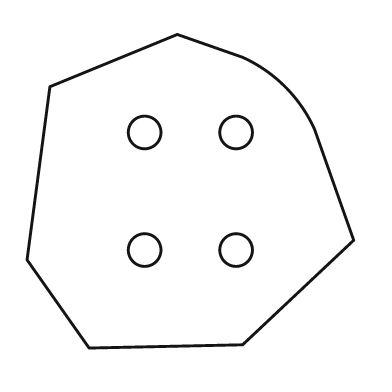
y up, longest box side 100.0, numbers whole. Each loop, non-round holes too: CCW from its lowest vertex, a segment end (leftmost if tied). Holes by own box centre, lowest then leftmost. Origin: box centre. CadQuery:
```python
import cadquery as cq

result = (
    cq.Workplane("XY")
    .moveTo(-31.0, -48.0)
    .lineTo(16.0, -47.0)
    .lineTo(50.0, -15.0)
    .lineTo(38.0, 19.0)
    .threePointArc((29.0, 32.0), (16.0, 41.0))
    .lineTo(-4.0, 48.0)
    .lineTo(-43.0, 32.0)
    .lineTo(-50.0, -21.0)
    .close()
    .moveTo(-14.0, -18.0)
    .circle(5.0)
    .moveTo(14.0, -18.0)
    .circle(5.0)
    .moveTo(-14.0, 18.0)
    .circle(5.0)
    .moveTo(14.0, 18.0)
    .circle(5.0)
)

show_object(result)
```